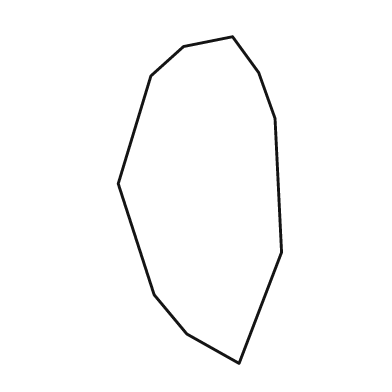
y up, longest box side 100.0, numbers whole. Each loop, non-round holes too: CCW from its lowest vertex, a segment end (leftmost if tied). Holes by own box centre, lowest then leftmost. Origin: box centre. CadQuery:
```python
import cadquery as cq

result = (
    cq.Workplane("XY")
    .moveTo(12.0, -50.0)
    .lineTo(25.0, -16.0)
    .lineTo(23.0, 25.0)
    .lineTo(18.0, 39.0)
    .lineTo(10.0, 50.0)
    .lineTo(-5.0, 47.0)
    .lineTo(-15.0, 38.0)
    .lineTo(-25.0, 5.0)
    .lineTo(-14.0, -29.0)
    .lineTo(-4.0, -41.0)
    .close()
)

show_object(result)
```